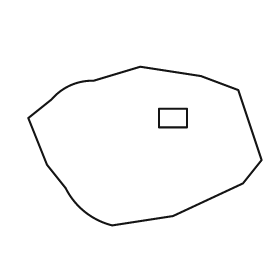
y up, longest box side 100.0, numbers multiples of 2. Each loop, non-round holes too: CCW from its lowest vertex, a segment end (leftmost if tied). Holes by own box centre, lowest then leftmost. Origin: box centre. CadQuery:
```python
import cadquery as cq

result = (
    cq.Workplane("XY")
    .moveTo(-14.0, -34.0)
    .lineTo(12.0, -30.0)
    .lineTo(42.0, -16.0)
    .lineTo(50.0, -6.0)
    .lineTo(40.0, 24.0)
    .lineTo(24.0, 30.0)
    .lineTo(-2.0, 34.0)
    .lineTo(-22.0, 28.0)
    .threePointArc((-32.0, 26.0), (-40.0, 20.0))
    .lineTo(-50.0, 12.0)
    .lineTo(-42.0, -8.0)
    .lineTo(-34.0, -18.0)
    .threePointArc((-26.0, -28.0), (-14.0, -34.0))
    .close()
    .moveTo(6.0, 8.0)
    .lineTo(18.0, 8.0)
    .lineTo(18.0, 16.0)
    .lineTo(6.0, 16.0)
    .close()
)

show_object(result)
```